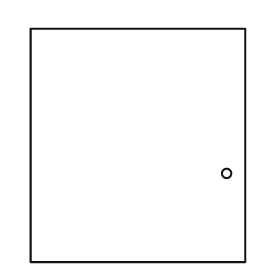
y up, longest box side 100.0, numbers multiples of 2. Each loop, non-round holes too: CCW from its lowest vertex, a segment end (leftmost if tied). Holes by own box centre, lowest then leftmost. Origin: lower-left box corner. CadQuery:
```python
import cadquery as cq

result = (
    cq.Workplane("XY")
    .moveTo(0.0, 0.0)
    .lineTo(92.0, 0.0)
    .lineTo(92.0, 100.0)
    .lineTo(0.0, 100.0)
    .close()
    .moveTo(84.0, 38.0)
    .circle(2.0)
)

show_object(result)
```